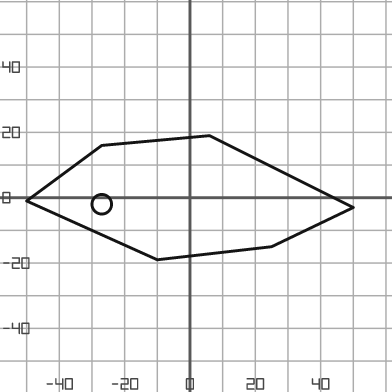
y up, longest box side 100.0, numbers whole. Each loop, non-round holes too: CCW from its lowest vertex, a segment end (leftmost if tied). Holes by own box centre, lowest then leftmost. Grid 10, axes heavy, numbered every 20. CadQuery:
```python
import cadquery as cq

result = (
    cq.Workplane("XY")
    .moveTo(-10.0, -19.0)
    .lineTo(25.0, -15.0)
    .lineTo(50.0, -3.0)
    .lineTo(6.0, 19.0)
    .lineTo(-27.0, 16.0)
    .lineTo(-50.0, -1.0)
    .close()
    .moveTo(-27.0, -2.0)
    .circle(3.0)
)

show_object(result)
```